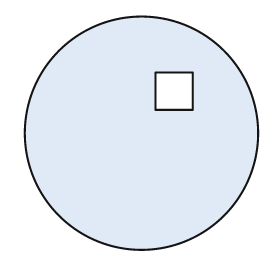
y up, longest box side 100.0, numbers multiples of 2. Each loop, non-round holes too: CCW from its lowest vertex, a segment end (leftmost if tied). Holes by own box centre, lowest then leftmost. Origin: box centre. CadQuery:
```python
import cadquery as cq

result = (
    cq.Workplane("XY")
    .moveTo(0.0, 0.0)
    .circle(50.0)
    .moveTo(6.0, 10.0)
    .lineTo(22.0, 10.0)
    .lineTo(22.0, 26.0)
    .lineTo(6.0, 26.0)
    .close()
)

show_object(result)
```